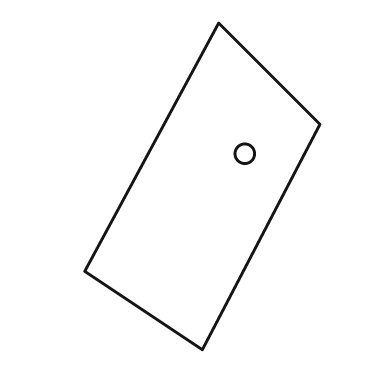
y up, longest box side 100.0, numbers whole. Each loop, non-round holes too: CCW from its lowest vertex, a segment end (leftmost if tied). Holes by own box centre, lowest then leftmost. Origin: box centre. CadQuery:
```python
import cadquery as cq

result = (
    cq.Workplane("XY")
    .moveTo(0.0, -50.0)
    .lineTo(36.0, 19.0)
    .lineTo(5.0, 50.0)
    .lineTo(-36.0, -26.0)
    .close()
    .moveTo(13.0, 10.0)
    .circle(3.0)
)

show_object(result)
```